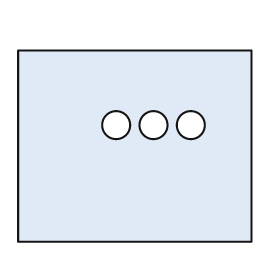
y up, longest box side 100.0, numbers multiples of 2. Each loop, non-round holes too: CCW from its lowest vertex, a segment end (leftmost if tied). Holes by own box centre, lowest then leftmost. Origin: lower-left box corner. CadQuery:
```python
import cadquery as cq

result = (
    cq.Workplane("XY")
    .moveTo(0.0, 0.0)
    .lineTo(100.0, 0.0)
    .lineTo(100.0, 82.0)
    .lineTo(0.0, 82.0)
    .close()
    .moveTo(42.0, 50.0)
    .circle(6.0)
    .moveTo(58.0, 50.0)
    .circle(6.0)
    .moveTo(74.0, 50.0)
    .circle(6.0)
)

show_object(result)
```